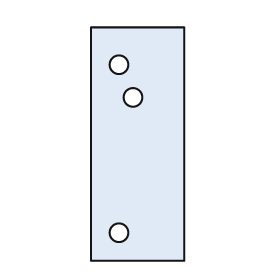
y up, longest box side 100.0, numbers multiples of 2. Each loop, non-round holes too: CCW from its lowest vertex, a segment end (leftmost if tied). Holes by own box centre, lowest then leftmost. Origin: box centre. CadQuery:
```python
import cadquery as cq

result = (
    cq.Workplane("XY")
    .moveTo(-20.0, -50.0)
    .lineTo(20.0, -50.0)
    .lineTo(20.0, 50.0)
    .lineTo(-20.0, 50.0)
    .close()
    .moveTo(-8.0, -38.0)
    .circle(4.0)
    .moveTo(-2.0, 20.0)
    .circle(4.0)
    .moveTo(-8.0, 34.0)
    .circle(4.0)
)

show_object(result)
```